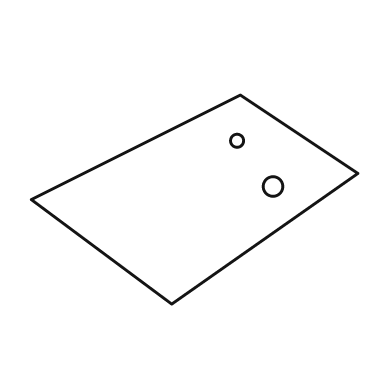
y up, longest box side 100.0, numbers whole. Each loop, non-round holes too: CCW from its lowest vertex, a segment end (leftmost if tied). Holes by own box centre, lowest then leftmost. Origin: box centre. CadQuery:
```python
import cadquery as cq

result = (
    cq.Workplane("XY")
    .moveTo(-7.0, -32.0)
    .lineTo(50.0, 8.0)
    .lineTo(14.0, 32.0)
    .lineTo(-50.0, 0.0)
    .close()
    .moveTo(24.0, 4.0)
    .circle(3.0)
    .moveTo(13.0, 18.0)
    .circle(2.0)
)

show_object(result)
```